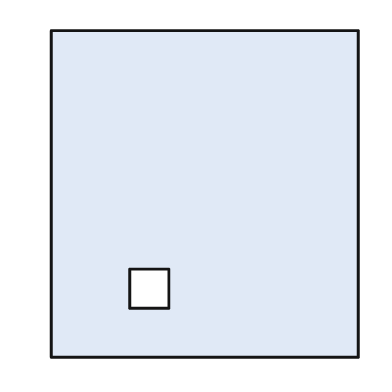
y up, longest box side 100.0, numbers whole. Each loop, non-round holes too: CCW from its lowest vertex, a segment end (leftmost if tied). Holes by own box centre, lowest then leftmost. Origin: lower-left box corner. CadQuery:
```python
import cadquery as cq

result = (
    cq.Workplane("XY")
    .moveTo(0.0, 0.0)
    .lineTo(94.0, 0.0)
    .lineTo(94.0, 100.0)
    .lineTo(0.0, 100.0)
    .close()
    .moveTo(24.0, 15.0)
    .lineTo(36.0, 15.0)
    .lineTo(36.0, 27.0)
    .lineTo(24.0, 27.0)
    .close()
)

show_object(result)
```